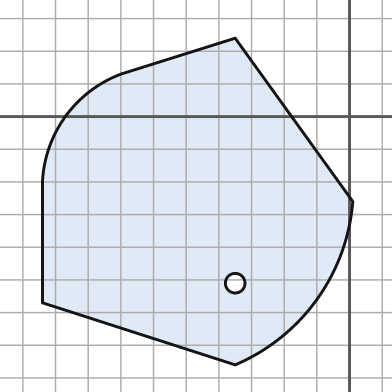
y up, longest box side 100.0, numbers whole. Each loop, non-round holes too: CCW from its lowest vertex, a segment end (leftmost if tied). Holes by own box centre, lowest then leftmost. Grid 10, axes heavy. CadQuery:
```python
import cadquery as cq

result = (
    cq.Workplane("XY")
    .moveTo(-35.0, -76.0)
    .threePointArc((-10.0, -56.0), (1.0, -26.0))
    .lineTo(-35.0, 24.0)
    .lineTo(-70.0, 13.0)
    .threePointArc((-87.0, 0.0), (-94.0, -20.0))
    .lineTo(-94.0, -57.0)
    .close()
    .moveTo(-35.0, -51.0)
    .circle(3.0)
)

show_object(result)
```